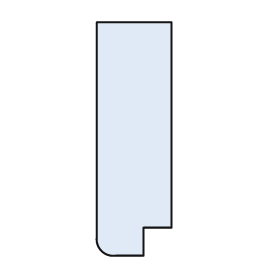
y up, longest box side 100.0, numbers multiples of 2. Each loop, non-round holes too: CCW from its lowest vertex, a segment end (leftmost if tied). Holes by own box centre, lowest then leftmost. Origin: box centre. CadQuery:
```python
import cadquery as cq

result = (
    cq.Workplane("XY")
    .moveTo(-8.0, -50.0)
    .lineTo(4.0, -50.0)
    .lineTo(4.0, -38.0)
    .lineTo(16.0, -38.0)
    .lineTo(16.0, 50.0)
    .lineTo(-16.0, 50.0)
    .lineTo(-16.0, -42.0)
    .threePointArc((-14.0, -48.0), (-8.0, -50.0))
    .close()
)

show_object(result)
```